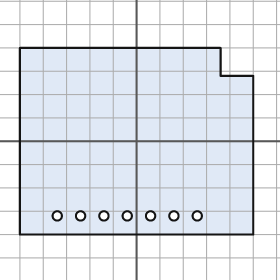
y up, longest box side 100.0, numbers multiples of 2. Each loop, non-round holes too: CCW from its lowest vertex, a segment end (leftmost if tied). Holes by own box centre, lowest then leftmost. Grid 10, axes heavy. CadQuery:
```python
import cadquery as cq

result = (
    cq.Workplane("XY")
    .moveTo(-50.0, -40.0)
    .lineTo(50.0, -40.0)
    .lineTo(50.0, 28.0)
    .lineTo(36.0, 28.0)
    .lineTo(36.0, 40.0)
    .lineTo(-50.0, 40.0)
    .close()
    .moveTo(-34.0, -32.0)
    .circle(2.0)
    .moveTo(-24.0, -32.0)
    .circle(2.0)
    .moveTo(-14.0, -32.0)
    .circle(2.0)
    .moveTo(-4.0, -32.0)
    .circle(2.0)
    .moveTo(6.0, -32.0)
    .circle(2.0)
    .moveTo(16.0, -32.0)
    .circle(2.0)
    .moveTo(26.0, -32.0)
    .circle(2.0)
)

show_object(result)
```